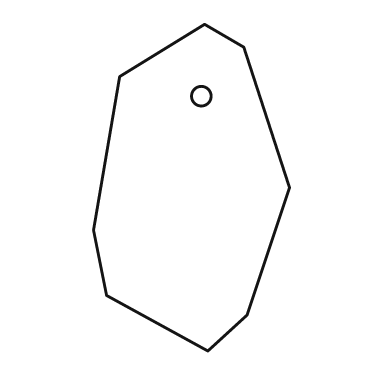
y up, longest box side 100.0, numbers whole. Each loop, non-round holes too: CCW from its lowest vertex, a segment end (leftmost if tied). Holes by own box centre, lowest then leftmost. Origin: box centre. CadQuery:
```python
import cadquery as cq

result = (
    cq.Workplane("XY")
    .moveTo(5.0, -50.0)
    .lineTo(17.0, -39.0)
    .lineTo(30.0, 0.0)
    .lineTo(16.0, 43.0)
    .lineTo(4.0, 50.0)
    .lineTo(-22.0, 34.0)
    .lineTo(-30.0, -13.0)
    .lineTo(-26.0, -33.0)
    .close()
    .moveTo(3.0, 28.0)
    .circle(3.0)
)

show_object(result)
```